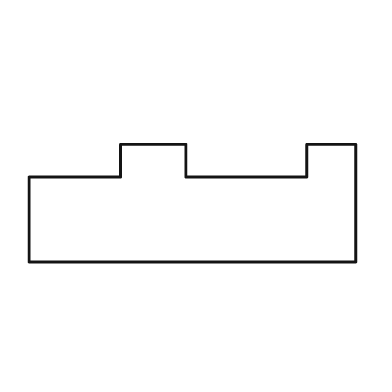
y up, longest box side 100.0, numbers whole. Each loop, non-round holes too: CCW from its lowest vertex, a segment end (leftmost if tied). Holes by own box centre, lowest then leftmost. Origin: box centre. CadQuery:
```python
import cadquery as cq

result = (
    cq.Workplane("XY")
    .moveTo(-50.0, -18.0)
    .lineTo(50.0, -18.0)
    .lineTo(50.0, 18.0)
    .lineTo(35.0, 18.0)
    .lineTo(35.0, 8.0)
    .lineTo(-2.0, 8.0)
    .lineTo(-2.0, 18.0)
    .lineTo(-22.0, 18.0)
    .lineTo(-22.0, 8.0)
    .lineTo(-50.0, 8.0)
    .close()
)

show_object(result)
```